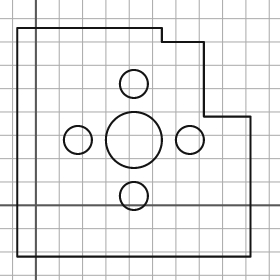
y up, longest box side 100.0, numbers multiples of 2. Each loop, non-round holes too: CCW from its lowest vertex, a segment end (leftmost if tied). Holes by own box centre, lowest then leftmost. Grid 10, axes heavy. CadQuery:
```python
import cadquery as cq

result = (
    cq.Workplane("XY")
    .moveTo(-8.0, -22.0)
    .lineTo(92.0, -22.0)
    .lineTo(92.0, 38.0)
    .lineTo(72.0, 38.0)
    .lineTo(72.0, 70.0)
    .lineTo(54.0, 70.0)
    .lineTo(54.0, 76.0)
    .lineTo(-8.0, 76.0)
    .close()
    .moveTo(42.0, 4.0)
    .circle(6.0)
    .moveTo(18.0, 28.0)
    .circle(6.0)
    .moveTo(42.0, 28.0)
    .circle(12.0)
    .moveTo(66.0, 28.0)
    .circle(6.0)
    .moveTo(42.0, 52.0)
    .circle(6.0)
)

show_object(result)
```